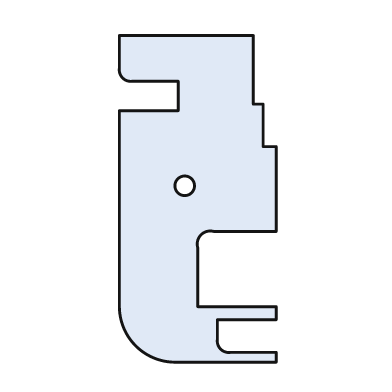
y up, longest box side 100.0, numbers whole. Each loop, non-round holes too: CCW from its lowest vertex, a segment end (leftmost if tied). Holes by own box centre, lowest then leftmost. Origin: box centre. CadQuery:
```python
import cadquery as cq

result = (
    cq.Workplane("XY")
    .moveTo(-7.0, -50.0)
    .lineTo(24.0, -50.0)
    .lineTo(24.0, -47.0)
    .lineTo(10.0, -47.0)
    .threePointArc((7.0, -46.0), (6.0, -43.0))
    .lineTo(6.0, -37.0)
    .lineTo(24.0, -37.0)
    .lineTo(24.0, -33.0)
    .lineTo(0.0, -33.0)
    .lineTo(0.0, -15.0)
    .threePointArc((1.0, -11.0), (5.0, -10.0))
    .lineTo(24.0, -10.0)
    .lineTo(24.0, 16.0)
    .lineTo(20.0, 16.0)
    .lineTo(20.0, 29.0)
    .lineTo(17.0, 29.0)
    .lineTo(17.0, 50.0)
    .lineTo(-24.0, 50.0)
    .lineTo(-24.0, 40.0)
    .threePointArc((-23.0, 37.0), (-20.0, 36.0))
    .lineTo(-6.0, 36.0)
    .lineTo(-6.0, 27.0)
    .lineTo(-24.0, 27.0)
    .lineTo(-24.0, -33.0)
    .threePointArc((-19.0, -45.0), (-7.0, -50.0))
    .close()
    .moveTo(-4.0, 4.0)
    .circle(3.0)
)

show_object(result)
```